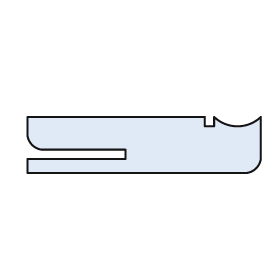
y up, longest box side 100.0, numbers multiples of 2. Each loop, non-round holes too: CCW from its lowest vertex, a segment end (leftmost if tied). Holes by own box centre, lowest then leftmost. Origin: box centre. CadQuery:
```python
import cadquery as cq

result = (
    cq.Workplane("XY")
    .moveTo(-50.0, -12.0)
    .lineTo(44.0, -12.0)
    .threePointArc((48.0, -10.0), (50.0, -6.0))
    .lineTo(50.0, 12.0)
    .threePointArc((40.0, 8.0), (30.0, 12.0))
    .lineTo(30.0, 8.0)
    .lineTo(26.0, 8.0)
    .lineTo(26.0, 12.0)
    .lineTo(-50.0, 12.0)
    .lineTo(-50.0, 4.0)
    .threePointArc((-48.0, 0.0), (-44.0, -2.0))
    .lineTo(-8.0, -2.0)
    .lineTo(-8.0, -6.0)
    .lineTo(-50.0, -6.0)
    .close()
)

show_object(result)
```